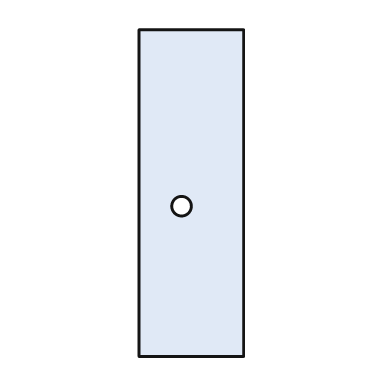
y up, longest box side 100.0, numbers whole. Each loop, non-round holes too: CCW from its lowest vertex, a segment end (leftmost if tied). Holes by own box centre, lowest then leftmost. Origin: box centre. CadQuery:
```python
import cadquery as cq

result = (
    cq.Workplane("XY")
    .moveTo(-16.0, -50.0)
    .lineTo(16.0, -50.0)
    .lineTo(16.0, 50.0)
    .lineTo(-16.0, 50.0)
    .close()
    .moveTo(-3.0, -4.0)
    .circle(3.0)
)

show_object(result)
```